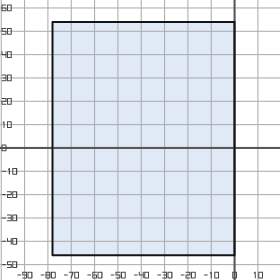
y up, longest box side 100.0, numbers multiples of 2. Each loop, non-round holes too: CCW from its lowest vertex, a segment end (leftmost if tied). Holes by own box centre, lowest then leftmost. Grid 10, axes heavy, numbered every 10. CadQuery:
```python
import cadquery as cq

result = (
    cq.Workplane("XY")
    .moveTo(-78.0, -46.0)
    .lineTo(0.0, -46.0)
    .lineTo(0.0, 54.0)
    .lineTo(-78.0, 54.0)
    .close()
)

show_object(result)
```